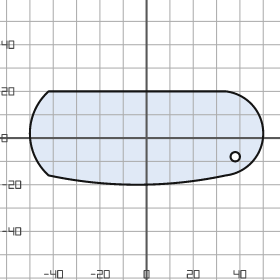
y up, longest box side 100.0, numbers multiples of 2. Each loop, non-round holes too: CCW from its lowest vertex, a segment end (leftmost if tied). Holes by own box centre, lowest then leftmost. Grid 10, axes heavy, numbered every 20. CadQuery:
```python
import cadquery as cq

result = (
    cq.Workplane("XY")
    .moveTo(-42.0, -16.0)
    .threePointArc((-4.0, -20.0), (34.0, -16.0))
    .threePointArc((50.0, 2.0), (34.0, 20.0))
    .lineTo(-42.0, 20.0)
    .threePointArc((-50.0, 2.0), (-42.0, -16.0))
    .close()
    .moveTo(38.0, -8.0)
    .circle(2.0)
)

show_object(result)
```